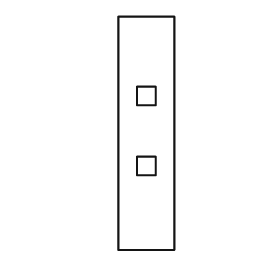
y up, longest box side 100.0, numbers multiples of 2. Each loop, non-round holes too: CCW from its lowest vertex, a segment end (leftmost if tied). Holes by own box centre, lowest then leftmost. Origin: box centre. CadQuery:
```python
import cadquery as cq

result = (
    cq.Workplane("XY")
    .moveTo(-12.0, -50.0)
    .lineTo(12.0, -50.0)
    .lineTo(12.0, 50.0)
    .lineTo(-12.0, 50.0)
    .close()
    .moveTo(-4.0, -18.0)
    .lineTo(4.0, -18.0)
    .lineTo(4.0, -10.0)
    .lineTo(-4.0, -10.0)
    .close()
    .moveTo(-4.0, 12.0)
    .lineTo(4.0, 12.0)
    .lineTo(4.0, 20.0)
    .lineTo(-4.0, 20.0)
    .close()
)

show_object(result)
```